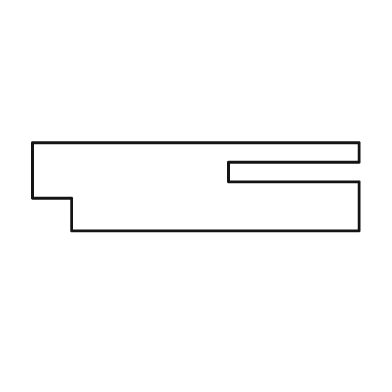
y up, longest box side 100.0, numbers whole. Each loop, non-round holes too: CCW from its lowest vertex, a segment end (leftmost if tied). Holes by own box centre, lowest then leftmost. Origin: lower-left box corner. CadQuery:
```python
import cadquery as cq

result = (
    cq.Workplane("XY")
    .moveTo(12.0, 0.0)
    .lineTo(100.0, 0.0)
    .lineTo(100.0, 15.0)
    .lineTo(60.0, 15.0)
    .lineTo(60.0, 21.0)
    .lineTo(100.0, 21.0)
    .lineTo(100.0, 27.0)
    .lineTo(0.0, 27.0)
    .lineTo(0.0, 10.0)
    .lineTo(12.0, 10.0)
    .close()
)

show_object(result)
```